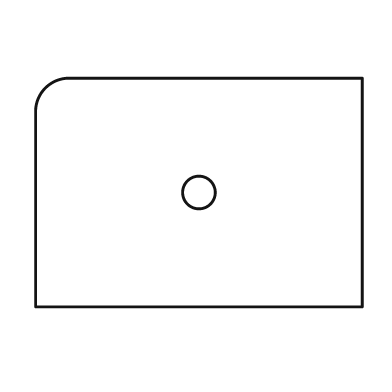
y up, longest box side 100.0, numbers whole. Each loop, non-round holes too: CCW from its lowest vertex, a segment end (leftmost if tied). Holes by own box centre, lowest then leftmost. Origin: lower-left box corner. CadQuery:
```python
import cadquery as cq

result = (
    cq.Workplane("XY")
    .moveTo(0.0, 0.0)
    .lineTo(100.0, 0.0)
    .lineTo(100.0, 70.0)
    .lineTo(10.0, 70.0)
    .threePointArc((3.0, 67.0), (0.0, 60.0))
    .close()
    .moveTo(50.0, 35.0)
    .circle(5.0)
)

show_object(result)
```